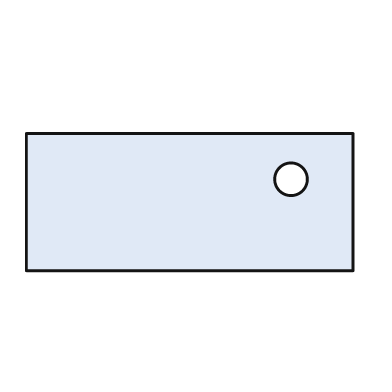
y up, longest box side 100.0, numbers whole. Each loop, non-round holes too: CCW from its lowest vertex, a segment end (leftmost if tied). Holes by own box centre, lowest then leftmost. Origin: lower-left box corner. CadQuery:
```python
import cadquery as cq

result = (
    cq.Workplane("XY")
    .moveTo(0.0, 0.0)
    .lineTo(100.0, 0.0)
    .lineTo(100.0, 42.0)
    .lineTo(0.0, 42.0)
    .close()
    .moveTo(81.0, 28.0)
    .circle(5.0)
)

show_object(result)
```